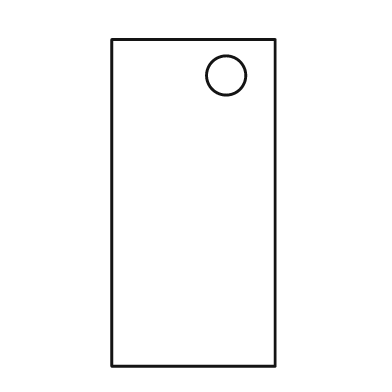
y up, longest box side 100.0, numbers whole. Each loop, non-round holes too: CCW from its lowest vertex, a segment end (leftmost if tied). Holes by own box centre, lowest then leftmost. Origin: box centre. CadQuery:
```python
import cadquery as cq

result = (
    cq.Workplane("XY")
    .moveTo(-25.0, -50.0)
    .lineTo(25.0, -50.0)
    .lineTo(25.0, 50.0)
    .lineTo(-25.0, 50.0)
    .close()
    .moveTo(10.0, 39.0)
    .circle(6.0)
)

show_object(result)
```